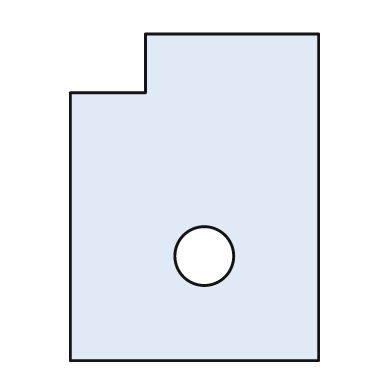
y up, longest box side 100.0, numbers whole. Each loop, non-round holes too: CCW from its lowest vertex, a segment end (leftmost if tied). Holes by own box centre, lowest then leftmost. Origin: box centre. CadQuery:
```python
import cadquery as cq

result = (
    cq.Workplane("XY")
    .moveTo(-38.0, -50.0)
    .lineTo(38.0, -50.0)
    .lineTo(38.0, 50.0)
    .lineTo(-15.0, 50.0)
    .lineTo(-15.0, 32.0)
    .lineTo(-38.0, 32.0)
    .close()
    .moveTo(3.0, -18.0)
    .circle(9.0)
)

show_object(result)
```